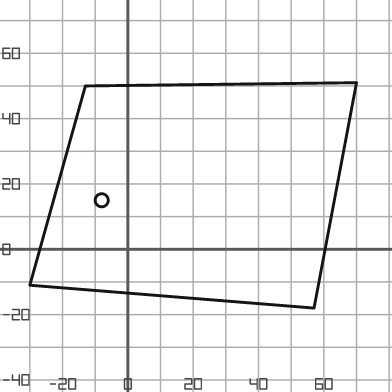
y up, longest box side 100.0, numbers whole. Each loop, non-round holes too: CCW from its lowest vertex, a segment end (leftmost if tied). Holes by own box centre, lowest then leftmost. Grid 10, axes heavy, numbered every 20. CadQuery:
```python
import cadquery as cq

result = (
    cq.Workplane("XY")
    .moveTo(57.0, -18.0)
    .lineTo(70.0, 51.0)
    .lineTo(-13.0, 50.0)
    .lineTo(-30.0, -11.0)
    .close()
    .moveTo(-8.0, 15.0)
    .circle(2.0)
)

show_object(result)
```